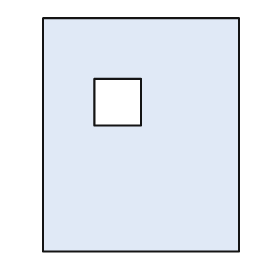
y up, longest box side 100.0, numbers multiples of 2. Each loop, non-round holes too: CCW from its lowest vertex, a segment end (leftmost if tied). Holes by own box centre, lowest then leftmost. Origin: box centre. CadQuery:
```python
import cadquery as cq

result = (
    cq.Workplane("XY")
    .moveTo(-42.0, -50.0)
    .lineTo(42.0, -50.0)
    .lineTo(42.0, 50.0)
    .lineTo(-42.0, 50.0)
    .close()
    .moveTo(-20.0, 4.0)
    .lineTo(0.0, 4.0)
    .lineTo(0.0, 24.0)
    .lineTo(-20.0, 24.0)
    .close()
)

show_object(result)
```